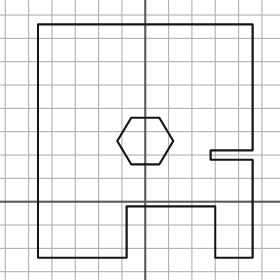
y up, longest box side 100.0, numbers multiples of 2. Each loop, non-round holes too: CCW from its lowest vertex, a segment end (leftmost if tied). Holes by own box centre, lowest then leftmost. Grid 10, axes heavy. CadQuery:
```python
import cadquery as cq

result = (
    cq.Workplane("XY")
    .moveTo(-46.0, -24.0)
    .lineTo(-8.0, -24.0)
    .lineTo(-8.0, -2.0)
    .lineTo(30.0, -2.0)
    .lineTo(30.0, -24.0)
    .lineTo(46.0, -24.0)
    .lineTo(46.0, 18.0)
    .lineTo(28.0, 18.0)
    .lineTo(28.0, 22.0)
    .lineTo(46.0, 22.0)
    .lineTo(46.0, 76.0)
    .lineTo(-46.0, 76.0)
    .close()
    .moveTo(-6.0, 16.0)
    .lineTo(6.0, 16.0)
    .lineTo(12.0, 26.0)
    .lineTo(6.0, 36.0)
    .lineTo(-6.0, 36.0)
    .lineTo(-12.0, 26.0)
    .close()
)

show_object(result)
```